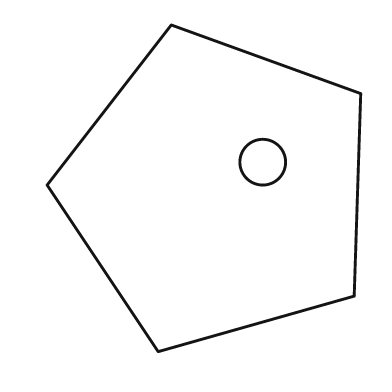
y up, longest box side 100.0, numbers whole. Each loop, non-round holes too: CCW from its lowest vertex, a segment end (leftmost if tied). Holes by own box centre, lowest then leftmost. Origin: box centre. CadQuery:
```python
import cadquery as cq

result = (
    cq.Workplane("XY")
    .moveTo(-14.0, -50.0)
    .lineTo(46.0, -33.0)
    .lineTo(48.0, 29.0)
    .lineTo(-10.0, 50.0)
    .lineTo(-48.0, 1.0)
    .close()
    .moveTo(18.0, 8.0)
    .circle(7.0)
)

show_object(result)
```